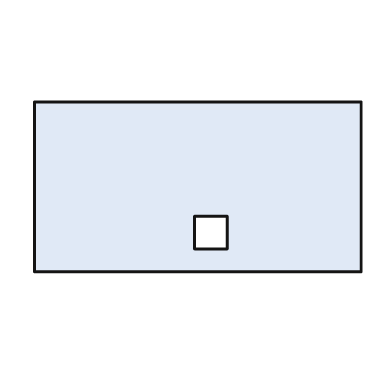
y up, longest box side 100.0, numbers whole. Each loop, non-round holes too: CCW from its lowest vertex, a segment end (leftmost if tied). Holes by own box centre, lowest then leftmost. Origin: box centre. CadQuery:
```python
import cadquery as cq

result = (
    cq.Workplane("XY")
    .moveTo(-50.0, -26.0)
    .lineTo(50.0, -26.0)
    .lineTo(50.0, 26.0)
    .lineTo(-50.0, 26.0)
    .close()
    .moveTo(-1.0, -19.0)
    .lineTo(9.0, -19.0)
    .lineTo(9.0, -9.0)
    .lineTo(-1.0, -9.0)
    .close()
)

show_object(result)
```